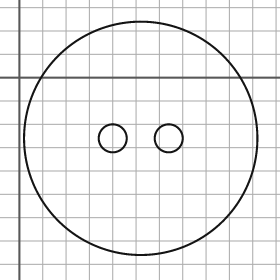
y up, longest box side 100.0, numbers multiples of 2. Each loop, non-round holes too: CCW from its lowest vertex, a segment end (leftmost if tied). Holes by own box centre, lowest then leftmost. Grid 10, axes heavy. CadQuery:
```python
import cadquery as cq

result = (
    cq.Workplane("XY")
    .moveTo(52.0, -26.0)
    .circle(50.0)
    .moveTo(40.0, -26.0)
    .circle(6.0)
    .moveTo(64.0, -26.0)
    .circle(6.0)
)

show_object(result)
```